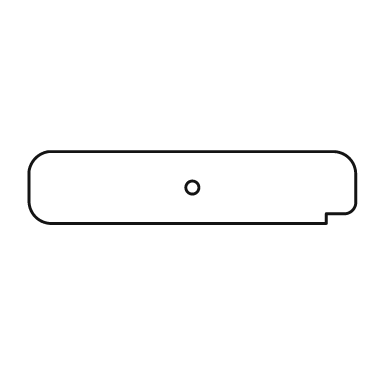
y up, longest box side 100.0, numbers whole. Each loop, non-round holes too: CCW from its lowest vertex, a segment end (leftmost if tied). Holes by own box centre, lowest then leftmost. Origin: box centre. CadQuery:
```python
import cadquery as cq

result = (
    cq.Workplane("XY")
    .moveTo(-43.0, -11.0)
    .lineTo(41.0, -11.0)
    .lineTo(41.0, -8.0)
    .lineTo(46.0, -8.0)
    .threePointArc((49.0, -7.0), (50.0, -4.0))
    .lineTo(50.0, 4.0)
    .threePointArc((48.0, 9.0), (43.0, 11.0))
    .lineTo(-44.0, 11.0)
    .threePointArc((-48.0, 9.0), (-50.0, 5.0))
    .lineTo(-50.0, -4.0)
    .threePointArc((-48.0, -9.0), (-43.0, -11.0))
    .close()
    .moveTo(0.0, 0.0)
    .circle(2.0)
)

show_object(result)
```